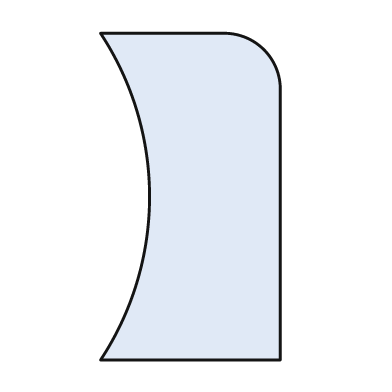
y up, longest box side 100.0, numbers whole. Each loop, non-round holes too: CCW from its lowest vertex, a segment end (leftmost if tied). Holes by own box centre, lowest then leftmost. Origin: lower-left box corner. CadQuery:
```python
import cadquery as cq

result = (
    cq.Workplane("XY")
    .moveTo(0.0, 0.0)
    .lineTo(55.0, 0.0)
    .lineTo(55.0, 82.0)
    .threePointArc((50.0, 95.0), (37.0, 100.0))
    .lineTo(0.0, 100.0)
    .threePointArc((15.0, 50.0), (0.0, 0.0))
    .close()
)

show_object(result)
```